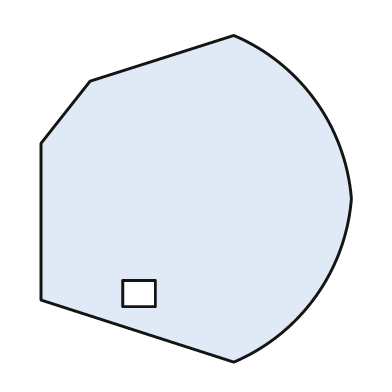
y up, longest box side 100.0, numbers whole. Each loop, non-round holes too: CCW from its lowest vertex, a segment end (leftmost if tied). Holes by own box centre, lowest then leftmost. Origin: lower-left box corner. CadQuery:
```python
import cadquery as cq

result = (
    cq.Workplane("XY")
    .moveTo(59.0, 0.0)
    .threePointArc((84.0, 20.0), (95.0, 50.0))
    .threePointArc((84.0, 80.0), (59.0, 100.0))
    .lineTo(15.0, 86.0)
    .lineTo(0.0, 67.0)
    .lineTo(0.0, 19.0)
    .close()
    .moveTo(25.0, 17.0)
    .lineTo(35.0, 17.0)
    .lineTo(35.0, 25.0)
    .lineTo(25.0, 25.0)
    .close()
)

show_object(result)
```